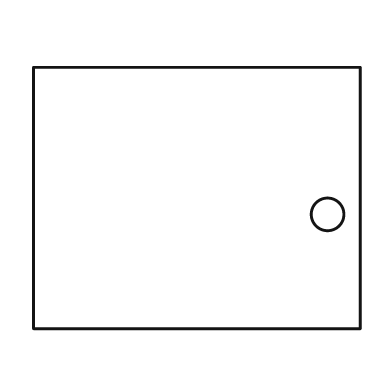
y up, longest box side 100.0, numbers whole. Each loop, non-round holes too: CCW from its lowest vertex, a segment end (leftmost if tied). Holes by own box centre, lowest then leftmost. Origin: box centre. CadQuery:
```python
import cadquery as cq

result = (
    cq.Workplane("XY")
    .moveTo(-50.0, -40.0)
    .lineTo(50.0, -40.0)
    .lineTo(50.0, 40.0)
    .lineTo(-50.0, 40.0)
    .close()
    .moveTo(40.0, -5.0)
    .circle(5.0)
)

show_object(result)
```